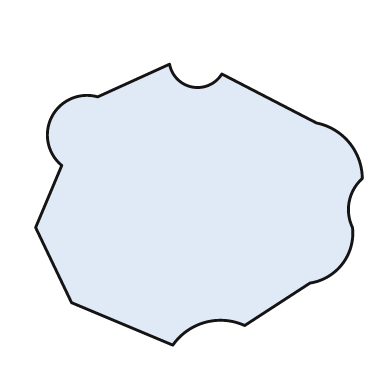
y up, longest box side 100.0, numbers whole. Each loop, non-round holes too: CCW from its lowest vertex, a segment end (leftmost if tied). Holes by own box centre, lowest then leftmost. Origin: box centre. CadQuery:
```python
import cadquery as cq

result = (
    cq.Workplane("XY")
    .moveTo(-8.0, -43.0)
    .threePointArc((2.0, -36.0), (14.0, -37.0))
    .lineTo(34.0, -24.0)
    .threePointArc((44.0, -18.0), (47.0, -7.0))
    .threePointArc((46.0, 1.0), (50.0, 8.0))
    .threePointArc((46.0, 19.0), (36.0, 25.0))
    .lineTo(7.0, 40.0)
    .threePointArc((-2.0, 36.0), (-9.0, 43.0))
    .lineTo(-31.0, 33.0)
    .threePointArc((-45.0, 27.0), (-42.0, 12.0))
    .lineTo(-50.0, -7.0)
    .lineTo(-39.0, -30.0)
    .close()
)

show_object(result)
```